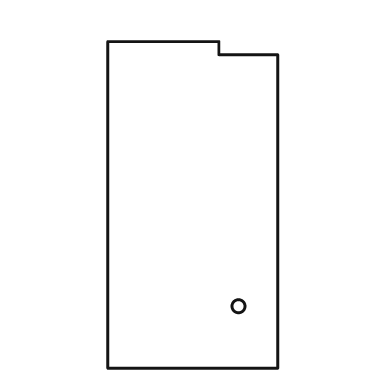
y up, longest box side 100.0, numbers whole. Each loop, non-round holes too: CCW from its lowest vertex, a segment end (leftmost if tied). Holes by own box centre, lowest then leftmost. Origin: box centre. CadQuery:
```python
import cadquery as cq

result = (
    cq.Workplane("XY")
    .moveTo(-26.0, -50.0)
    .lineTo(26.0, -50.0)
    .lineTo(26.0, 46.0)
    .lineTo(8.0, 46.0)
    .lineTo(8.0, 50.0)
    .lineTo(-26.0, 50.0)
    .close()
    .moveTo(14.0, -31.0)
    .circle(2.0)
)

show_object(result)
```